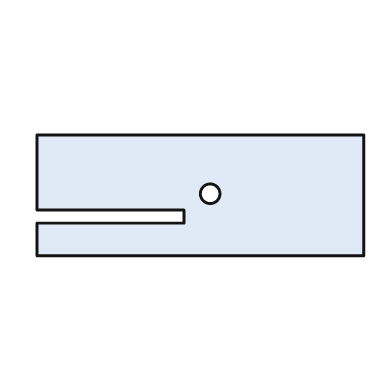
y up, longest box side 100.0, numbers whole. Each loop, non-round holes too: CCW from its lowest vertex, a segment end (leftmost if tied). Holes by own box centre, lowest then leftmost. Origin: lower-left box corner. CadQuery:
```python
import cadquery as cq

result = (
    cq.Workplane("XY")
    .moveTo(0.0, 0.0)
    .lineTo(100.0, 0.0)
    .lineTo(100.0, 37.0)
    .lineTo(0.0, 37.0)
    .lineTo(0.0, 14.0)
    .lineTo(45.0, 14.0)
    .lineTo(45.0, 10.0)
    .lineTo(0.0, 10.0)
    .close()
    .moveTo(53.0, 19.0)
    .circle(3.0)
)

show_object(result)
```